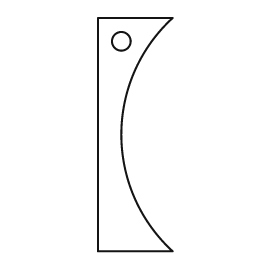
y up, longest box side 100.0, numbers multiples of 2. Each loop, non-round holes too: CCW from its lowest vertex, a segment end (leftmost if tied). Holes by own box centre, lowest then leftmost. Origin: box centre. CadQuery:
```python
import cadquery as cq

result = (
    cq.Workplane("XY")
    .moveTo(-16.0, -50.0)
    .lineTo(16.0, -50.0)
    .threePointArc((-6.0, 0.0), (16.0, 50.0))
    .lineTo(-16.0, 50.0)
    .close()
    .moveTo(-6.0, 40.0)
    .circle(4.0)
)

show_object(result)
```